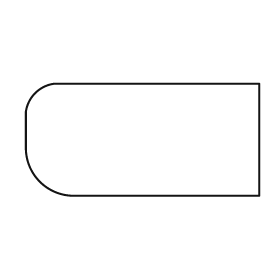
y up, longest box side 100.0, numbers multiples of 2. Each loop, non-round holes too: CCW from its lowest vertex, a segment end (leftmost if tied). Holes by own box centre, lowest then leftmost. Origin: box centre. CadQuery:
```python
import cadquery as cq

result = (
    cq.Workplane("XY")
    .moveTo(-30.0, -24.0)
    .lineTo(50.0, -24.0)
    .lineTo(50.0, 24.0)
    .lineTo(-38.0, 24.0)
    .threePointArc((-46.0, 20.0), (-50.0, 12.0))
    .lineTo(-50.0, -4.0)
    .threePointArc((-44.0, -18.0), (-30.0, -24.0))
    .close()
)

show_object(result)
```